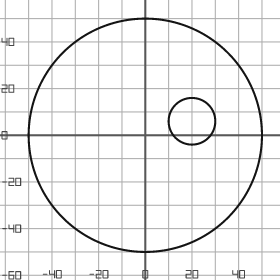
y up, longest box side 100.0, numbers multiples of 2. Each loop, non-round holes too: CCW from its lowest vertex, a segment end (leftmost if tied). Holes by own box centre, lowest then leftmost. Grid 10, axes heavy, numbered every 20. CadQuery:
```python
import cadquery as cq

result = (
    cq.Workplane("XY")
    .moveTo(0.0, 0.0)
    .circle(50.0)
    .moveTo(20.0, 6.0)
    .circle(10.0)
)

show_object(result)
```